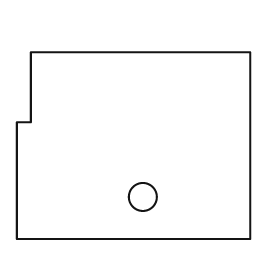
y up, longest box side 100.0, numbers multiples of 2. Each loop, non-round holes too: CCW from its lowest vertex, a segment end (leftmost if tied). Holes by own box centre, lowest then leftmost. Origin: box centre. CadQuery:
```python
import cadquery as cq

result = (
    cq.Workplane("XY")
    .moveTo(-50.0, -40.0)
    .lineTo(50.0, -40.0)
    .lineTo(50.0, 40.0)
    .lineTo(-44.0, 40.0)
    .lineTo(-44.0, 10.0)
    .lineTo(-50.0, 10.0)
    .close()
    .moveTo(4.0, -22.0)
    .circle(6.0)
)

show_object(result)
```